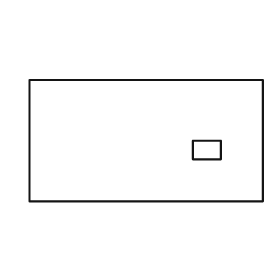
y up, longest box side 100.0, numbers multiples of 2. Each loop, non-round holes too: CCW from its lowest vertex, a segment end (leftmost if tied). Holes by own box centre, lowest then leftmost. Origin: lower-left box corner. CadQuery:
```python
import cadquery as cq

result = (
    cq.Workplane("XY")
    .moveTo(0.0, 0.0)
    .lineTo(100.0, 0.0)
    .lineTo(100.0, 52.0)
    .lineTo(0.0, 52.0)
    .close()
    .moveTo(70.0, 18.0)
    .lineTo(82.0, 18.0)
    .lineTo(82.0, 26.0)
    .lineTo(70.0, 26.0)
    .close()
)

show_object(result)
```